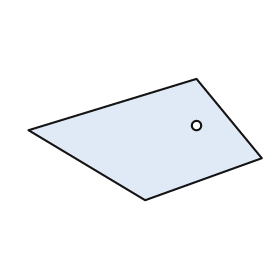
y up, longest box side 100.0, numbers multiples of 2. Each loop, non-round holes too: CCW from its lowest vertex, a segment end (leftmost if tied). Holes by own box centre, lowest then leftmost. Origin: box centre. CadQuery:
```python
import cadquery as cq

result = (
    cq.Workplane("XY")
    .moveTo(0.0, -26.0)
    .lineTo(50.0, -8.0)
    .lineTo(22.0, 26.0)
    .lineTo(-50.0, 4.0)
    .close()
    .moveTo(22.0, 6.0)
    .circle(2.0)
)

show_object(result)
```